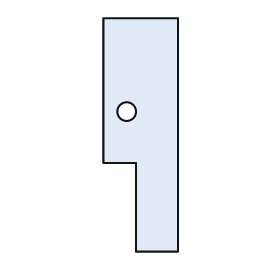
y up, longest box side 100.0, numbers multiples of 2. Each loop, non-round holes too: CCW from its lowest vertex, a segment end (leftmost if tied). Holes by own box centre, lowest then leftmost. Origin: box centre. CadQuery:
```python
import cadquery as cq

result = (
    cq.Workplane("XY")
    .moveTo(-2.0, -50.0)
    .lineTo(16.0, -50.0)
    .lineTo(16.0, 50.0)
    .lineTo(-16.0, 50.0)
    .lineTo(-16.0, -12.0)
    .lineTo(-2.0, -12.0)
    .close()
    .moveTo(-6.0, 10.0)
    .circle(4.0)
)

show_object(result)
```